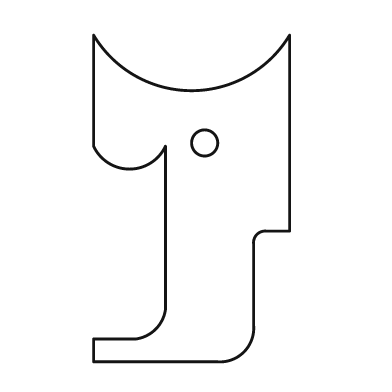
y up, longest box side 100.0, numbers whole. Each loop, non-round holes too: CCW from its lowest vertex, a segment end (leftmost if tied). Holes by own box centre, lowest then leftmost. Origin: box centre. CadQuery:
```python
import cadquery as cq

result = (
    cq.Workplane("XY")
    .moveTo(-30.0, -50.0)
    .lineTo(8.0, -50.0)
    .threePointArc((16.0, -47.0), (19.0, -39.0))
    .lineTo(19.0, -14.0)
    .threePointArc((20.0, -11.0), (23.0, -10.0))
    .lineTo(30.0, -10.0)
    .lineTo(30.0, 50.0)
    .threePointArc((0.0, 33.0), (-30.0, 50.0))
    .lineTo(-30.0, 16.0)
    .threePointArc((-19.0, 9.0), (-8.0, 16.0))
    .lineTo(-8.0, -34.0)
    .threePointArc((-11.0, -40.0), (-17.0, -43.0))
    .lineTo(-30.0, -43.0)
    .close()
    .moveTo(4.0, 17.0)
    .circle(4.0)
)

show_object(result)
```